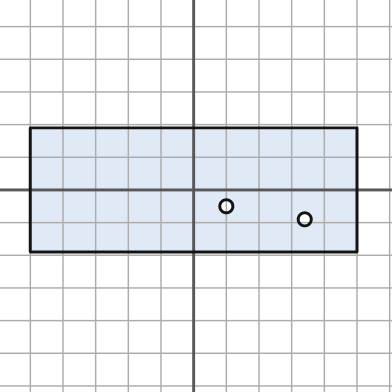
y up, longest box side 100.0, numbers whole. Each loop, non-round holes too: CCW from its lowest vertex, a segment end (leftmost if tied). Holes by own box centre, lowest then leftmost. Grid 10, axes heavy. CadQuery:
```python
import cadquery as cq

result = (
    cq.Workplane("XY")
    .moveTo(-50.0, -19.0)
    .lineTo(50.0, -19.0)
    .lineTo(50.0, 19.0)
    .lineTo(-50.0, 19.0)
    .close()
    .moveTo(34.0, -9.0)
    .circle(2.0)
    .moveTo(10.0, -5.0)
    .circle(2.0)
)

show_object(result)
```